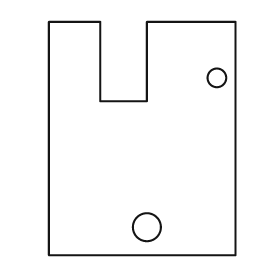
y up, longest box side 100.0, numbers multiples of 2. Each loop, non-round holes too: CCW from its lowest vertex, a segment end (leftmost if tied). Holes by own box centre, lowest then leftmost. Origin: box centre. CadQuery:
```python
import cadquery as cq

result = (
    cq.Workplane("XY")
    .moveTo(-40.0, -50.0)
    .lineTo(40.0, -50.0)
    .lineTo(40.0, 50.0)
    .lineTo(2.0, 50.0)
    .lineTo(2.0, 16.0)
    .lineTo(-18.0, 16.0)
    .lineTo(-18.0, 50.0)
    .lineTo(-40.0, 50.0)
    .close()
    .moveTo(2.0, -38.0)
    .circle(6.0)
    .moveTo(32.0, 26.0)
    .circle(4.0)
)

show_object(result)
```